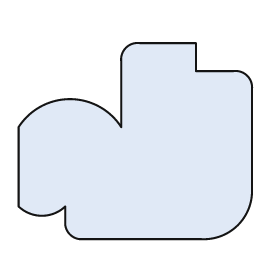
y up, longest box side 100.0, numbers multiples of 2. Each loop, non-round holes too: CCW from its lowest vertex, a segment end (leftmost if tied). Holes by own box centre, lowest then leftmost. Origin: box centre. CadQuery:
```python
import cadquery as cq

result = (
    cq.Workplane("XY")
    .moveTo(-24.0, -42.0)
    .lineTo(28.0, -42.0)
    .threePointArc((44.0, -36.0), (50.0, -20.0))
    .lineTo(50.0, 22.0)
    .threePointArc((48.0, 28.0), (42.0, 30.0))
    .lineTo(26.0, 30.0)
    .lineTo(26.0, 42.0)
    .lineTo(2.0, 42.0)
    .threePointArc((-4.0, 40.0), (-6.0, 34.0))
    .lineTo(-6.0, 6.0)
    .threePointArc((-28.0, 18.0), (-50.0, 6.0))
    .lineTo(-50.0, -28.0)
    .threePointArc((-40.0, -32.0), (-30.0, -28.0))
    .lineTo(-30.0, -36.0)
    .threePointArc((-28.0, -40.0), (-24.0, -42.0))
    .close()
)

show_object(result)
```